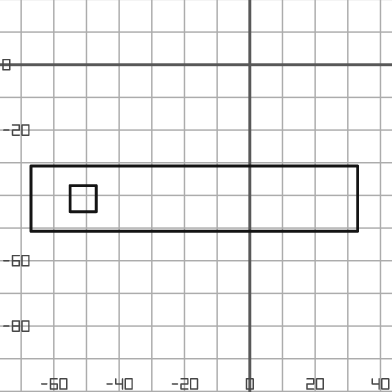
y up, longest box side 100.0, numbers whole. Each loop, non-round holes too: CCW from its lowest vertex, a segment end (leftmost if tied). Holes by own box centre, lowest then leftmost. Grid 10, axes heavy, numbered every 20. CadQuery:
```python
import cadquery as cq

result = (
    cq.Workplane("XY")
    .moveTo(-67.0, -51.0)
    .lineTo(33.0, -51.0)
    .lineTo(33.0, -31.0)
    .lineTo(-67.0, -31.0)
    .close()
    .moveTo(-55.0, -45.0)
    .lineTo(-47.0, -45.0)
    .lineTo(-47.0, -37.0)
    .lineTo(-55.0, -37.0)
    .close()
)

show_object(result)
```